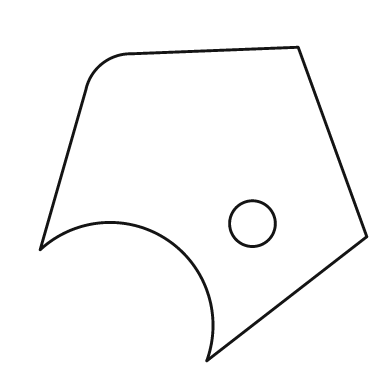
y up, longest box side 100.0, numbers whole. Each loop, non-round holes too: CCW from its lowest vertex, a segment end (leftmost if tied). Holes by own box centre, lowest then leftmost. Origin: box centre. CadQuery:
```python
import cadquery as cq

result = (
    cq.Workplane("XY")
    .moveTo(1.0, -48.0)
    .lineTo(50.0, -10.0)
    .lineTo(29.0, 48.0)
    .lineTo(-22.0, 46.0)
    .threePointArc((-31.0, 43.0), (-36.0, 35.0))
    .lineTo(-50.0, -14.0)
    .threePointArc((-11.0, -11.0), (1.0, -48.0))
    .close()
    .moveTo(15.0, -6.0)
    .circle(7.0)
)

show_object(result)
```